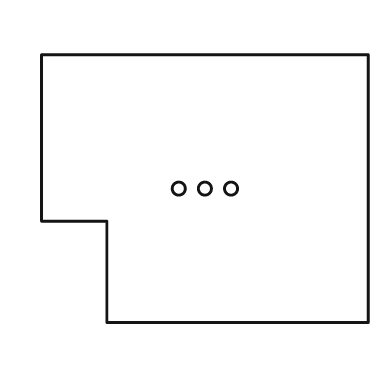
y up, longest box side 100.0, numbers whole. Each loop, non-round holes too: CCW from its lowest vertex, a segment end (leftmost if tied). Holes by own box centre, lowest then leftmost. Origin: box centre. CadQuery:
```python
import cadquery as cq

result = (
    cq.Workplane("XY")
    .moveTo(-30.0, -41.0)
    .lineTo(50.0, -41.0)
    .lineTo(50.0, 41.0)
    .lineTo(-50.0, 41.0)
    .lineTo(-50.0, -10.0)
    .lineTo(-30.0, -10.0)
    .close()
    .moveTo(-8.0, 0.0)
    .circle(2.0)
    .moveTo(0.0, 0.0)
    .circle(2.0)
    .moveTo(8.0, 0.0)
    .circle(2.0)
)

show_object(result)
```